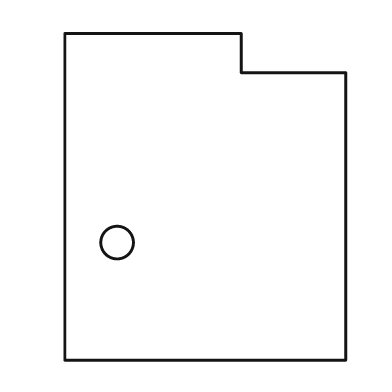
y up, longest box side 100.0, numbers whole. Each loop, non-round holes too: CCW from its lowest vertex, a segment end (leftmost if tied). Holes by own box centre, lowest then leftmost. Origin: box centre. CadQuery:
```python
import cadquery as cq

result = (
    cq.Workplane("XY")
    .moveTo(-43.0, -50.0)
    .lineTo(43.0, -50.0)
    .lineTo(43.0, 38.0)
    .lineTo(11.0, 38.0)
    .lineTo(11.0, 50.0)
    .lineTo(-43.0, 50.0)
    .close()
    .moveTo(-27.0, -14.0)
    .circle(5.0)
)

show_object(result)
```